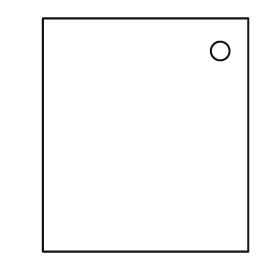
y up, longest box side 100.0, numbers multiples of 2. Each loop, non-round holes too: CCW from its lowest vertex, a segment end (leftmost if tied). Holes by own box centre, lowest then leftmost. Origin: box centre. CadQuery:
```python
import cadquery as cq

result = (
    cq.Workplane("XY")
    .moveTo(-44.0, -50.0)
    .lineTo(44.0, -50.0)
    .lineTo(44.0, 50.0)
    .lineTo(-44.0, 50.0)
    .close()
    .moveTo(32.0, 36.0)
    .circle(4.0)
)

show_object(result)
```